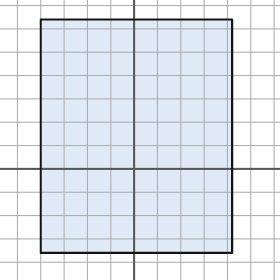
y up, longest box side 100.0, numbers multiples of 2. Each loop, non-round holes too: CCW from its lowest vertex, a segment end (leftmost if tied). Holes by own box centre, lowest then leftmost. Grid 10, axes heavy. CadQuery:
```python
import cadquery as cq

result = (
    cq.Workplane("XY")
    .moveTo(-40.0, -36.0)
    .lineTo(42.0, -36.0)
    .lineTo(42.0, 64.0)
    .lineTo(-40.0, 64.0)
    .close()
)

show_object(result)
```